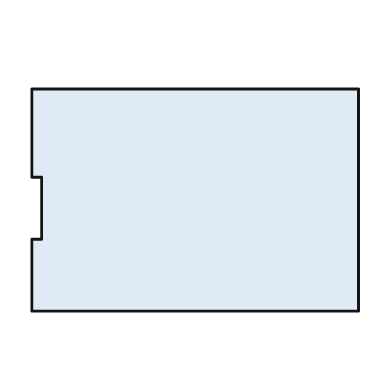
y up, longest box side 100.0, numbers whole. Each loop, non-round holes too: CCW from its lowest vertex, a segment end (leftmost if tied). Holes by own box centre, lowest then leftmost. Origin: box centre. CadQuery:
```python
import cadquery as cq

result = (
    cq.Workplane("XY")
    .moveTo(-50.0, -34.0)
    .lineTo(50.0, -34.0)
    .lineTo(50.0, 34.0)
    .lineTo(-50.0, 34.0)
    .lineTo(-50.0, 7.0)
    .lineTo(-47.0, 7.0)
    .lineTo(-47.0, -12.0)
    .lineTo(-50.0, -12.0)
    .close()
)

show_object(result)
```